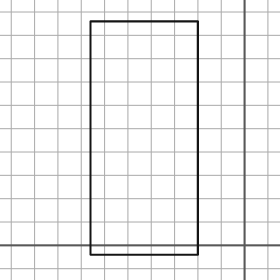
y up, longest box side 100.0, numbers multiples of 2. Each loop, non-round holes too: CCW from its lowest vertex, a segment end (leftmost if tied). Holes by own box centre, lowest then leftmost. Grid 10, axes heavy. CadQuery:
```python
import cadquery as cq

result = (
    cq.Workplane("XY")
    .moveTo(-66.0, -4.0)
    .lineTo(-20.0, -4.0)
    .lineTo(-20.0, 96.0)
    .lineTo(-66.0, 96.0)
    .close()
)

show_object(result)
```